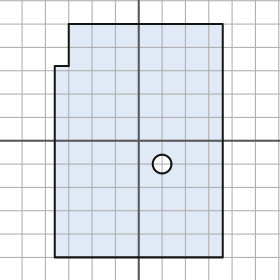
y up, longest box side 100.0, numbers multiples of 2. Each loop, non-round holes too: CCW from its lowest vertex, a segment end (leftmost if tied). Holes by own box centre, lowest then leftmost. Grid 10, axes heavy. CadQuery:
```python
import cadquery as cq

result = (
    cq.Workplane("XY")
    .moveTo(-36.0, -50.0)
    .lineTo(36.0, -50.0)
    .lineTo(36.0, 50.0)
    .lineTo(-30.0, 50.0)
    .lineTo(-30.0, 32.0)
    .lineTo(-36.0, 32.0)
    .close()
    .moveTo(10.0, -10.0)
    .circle(4.0)
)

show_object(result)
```